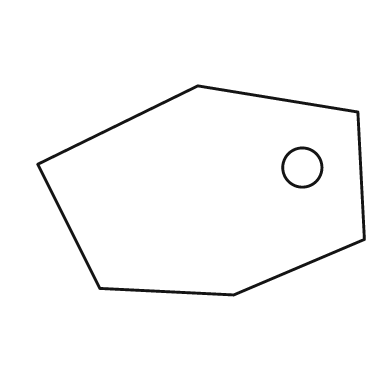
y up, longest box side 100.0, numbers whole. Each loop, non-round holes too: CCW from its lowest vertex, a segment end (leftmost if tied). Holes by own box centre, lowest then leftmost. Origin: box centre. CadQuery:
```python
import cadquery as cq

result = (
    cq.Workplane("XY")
    .moveTo(10.0, -32.0)
    .lineTo(50.0, -15.0)
    .lineTo(48.0, 24.0)
    .lineTo(-1.0, 32.0)
    .lineTo(-50.0, 8.0)
    .lineTo(-31.0, -30.0)
    .close()
    .moveTo(31.0, 7.0)
    .circle(6.0)
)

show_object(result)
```